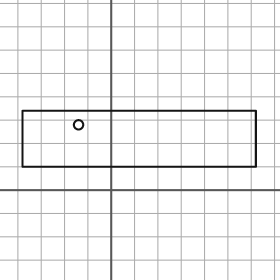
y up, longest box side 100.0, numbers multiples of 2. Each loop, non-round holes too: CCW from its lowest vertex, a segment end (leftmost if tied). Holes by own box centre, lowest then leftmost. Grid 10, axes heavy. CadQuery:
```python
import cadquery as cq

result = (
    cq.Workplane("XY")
    .moveTo(-38.0, 10.0)
    .lineTo(62.0, 10.0)
    .lineTo(62.0, 34.0)
    .lineTo(-38.0, 34.0)
    .close()
    .moveTo(-14.0, 28.0)
    .circle(2.0)
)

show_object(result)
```